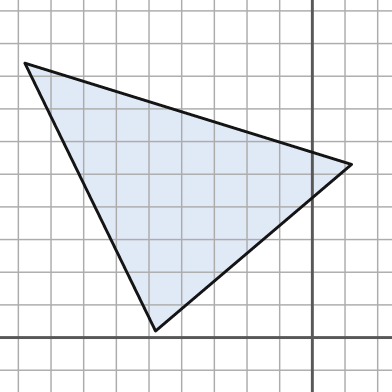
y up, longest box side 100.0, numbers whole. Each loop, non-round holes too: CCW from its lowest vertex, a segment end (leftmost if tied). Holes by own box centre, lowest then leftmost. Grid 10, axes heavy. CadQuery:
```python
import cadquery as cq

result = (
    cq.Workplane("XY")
    .moveTo(-48.0, 2.0)
    .lineTo(12.0, 53.0)
    .lineTo(-88.0, 84.0)
    .close()
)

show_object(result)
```